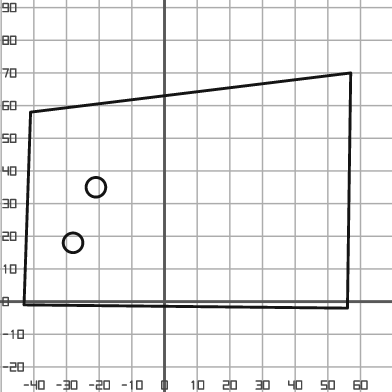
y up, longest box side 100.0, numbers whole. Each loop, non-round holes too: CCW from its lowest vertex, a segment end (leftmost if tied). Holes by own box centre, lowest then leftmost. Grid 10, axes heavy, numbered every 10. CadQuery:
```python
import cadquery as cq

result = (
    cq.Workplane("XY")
    .moveTo(56.0, -2.0)
    .lineTo(57.0, 70.0)
    .lineTo(-41.0, 58.0)
    .lineTo(-43.0, -1.0)
    .close()
    .moveTo(-28.0, 18.0)
    .circle(3.0)
    .moveTo(-21.0, 35.0)
    .circle(3.0)
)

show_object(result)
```